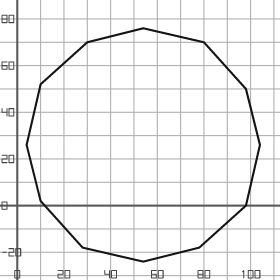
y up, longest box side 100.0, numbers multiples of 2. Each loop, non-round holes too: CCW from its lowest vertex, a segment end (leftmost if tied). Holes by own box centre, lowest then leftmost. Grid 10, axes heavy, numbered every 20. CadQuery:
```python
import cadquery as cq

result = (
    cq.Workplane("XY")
    .moveTo(54.0, -24.0)
    .lineTo(78.0, -18.0)
    .lineTo(98.0, 0.0)
    .lineTo(104.0, 26.0)
    .lineTo(98.0, 50.0)
    .lineTo(80.0, 70.0)
    .lineTo(54.0, 76.0)
    .lineTo(30.0, 70.0)
    .lineTo(10.0, 52.0)
    .lineTo(4.0, 26.0)
    .lineTo(10.0, 2.0)
    .lineTo(28.0, -18.0)
    .close()
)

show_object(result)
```